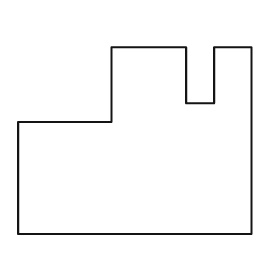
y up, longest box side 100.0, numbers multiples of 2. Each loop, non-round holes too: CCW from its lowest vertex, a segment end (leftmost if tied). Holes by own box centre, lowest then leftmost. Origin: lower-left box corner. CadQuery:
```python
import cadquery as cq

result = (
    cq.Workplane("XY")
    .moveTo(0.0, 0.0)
    .lineTo(100.0, 0.0)
    .lineTo(100.0, 80.0)
    .lineTo(84.0, 80.0)
    .lineTo(84.0, 56.0)
    .lineTo(72.0, 56.0)
    .lineTo(72.0, 80.0)
    .lineTo(40.0, 80.0)
    .lineTo(40.0, 48.0)
    .lineTo(0.0, 48.0)
    .close()
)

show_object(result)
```